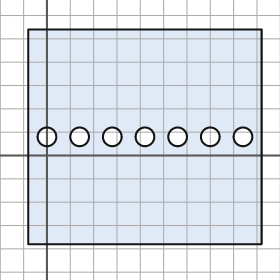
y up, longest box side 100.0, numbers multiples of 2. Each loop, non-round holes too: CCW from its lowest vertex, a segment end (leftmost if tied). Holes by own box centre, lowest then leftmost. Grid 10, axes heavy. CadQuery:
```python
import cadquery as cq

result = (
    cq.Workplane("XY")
    .moveTo(-8.0, -38.0)
    .lineTo(92.0, -38.0)
    .lineTo(92.0, 54.0)
    .lineTo(-8.0, 54.0)
    .close()
    .moveTo(0.0, 8.0)
    .circle(4.0)
    .moveTo(14.0, 8.0)
    .circle(4.0)
    .moveTo(28.0, 8.0)
    .circle(4.0)
    .moveTo(42.0, 8.0)
    .circle(4.0)
    .moveTo(56.0, 8.0)
    .circle(4.0)
    .moveTo(70.0, 8.0)
    .circle(4.0)
    .moveTo(84.0, 8.0)
    .circle(4.0)
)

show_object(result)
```